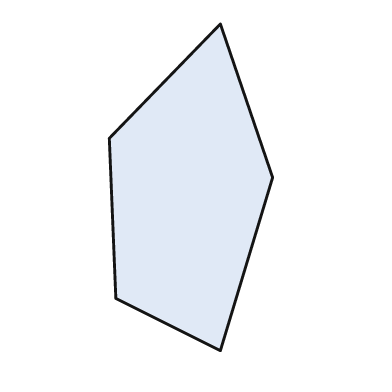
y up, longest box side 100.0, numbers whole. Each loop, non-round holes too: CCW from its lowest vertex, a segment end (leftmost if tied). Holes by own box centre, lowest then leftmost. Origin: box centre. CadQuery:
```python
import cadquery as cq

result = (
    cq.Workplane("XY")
    .moveTo(9.0, -50.0)
    .lineTo(25.0, 3.0)
    .lineTo(9.0, 50.0)
    .lineTo(-25.0, 15.0)
    .lineTo(-23.0, -34.0)
    .close()
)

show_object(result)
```